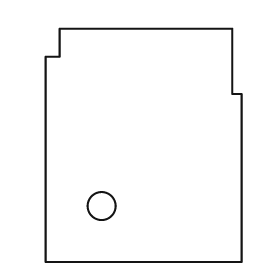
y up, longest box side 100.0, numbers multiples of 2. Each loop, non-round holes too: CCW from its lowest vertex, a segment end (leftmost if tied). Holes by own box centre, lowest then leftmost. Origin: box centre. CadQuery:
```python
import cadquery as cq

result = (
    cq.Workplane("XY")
    .moveTo(-42.0, -50.0)
    .lineTo(42.0, -50.0)
    .lineTo(42.0, 22.0)
    .lineTo(38.0, 22.0)
    .lineTo(38.0, 50.0)
    .lineTo(-36.0, 50.0)
    .lineTo(-36.0, 38.0)
    .lineTo(-42.0, 38.0)
    .close()
    .moveTo(-18.0, -26.0)
    .circle(6.0)
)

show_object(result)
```